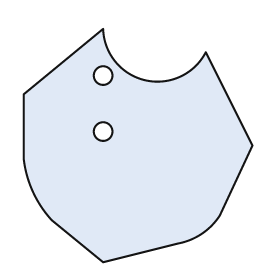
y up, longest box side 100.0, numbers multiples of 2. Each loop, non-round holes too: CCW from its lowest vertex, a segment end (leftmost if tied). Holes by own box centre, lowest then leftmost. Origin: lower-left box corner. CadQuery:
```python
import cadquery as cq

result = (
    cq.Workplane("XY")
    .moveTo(34.0, 0.0)
    .lineTo(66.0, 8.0)
    .threePointArc((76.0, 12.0), (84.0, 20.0))
    .lineTo(98.0, 50.0)
    .lineTo(78.0, 90.0)
    .threePointArc((52.0, 78.0), (34.0, 100.0))
    .lineTo(0.0, 72.0)
    .lineTo(0.0, 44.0)
    .threePointArc((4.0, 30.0), (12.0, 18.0))
    .close()
    .moveTo(34.0, 56.0)
    .circle(4.0)
    .moveTo(34.0, 80.0)
    .circle(4.0)
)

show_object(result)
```